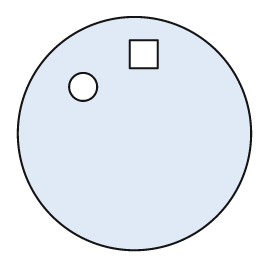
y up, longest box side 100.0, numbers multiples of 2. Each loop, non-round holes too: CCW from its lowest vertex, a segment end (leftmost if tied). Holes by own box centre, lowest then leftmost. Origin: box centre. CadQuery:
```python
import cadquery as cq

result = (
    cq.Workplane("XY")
    .moveTo(0.0, 0.0)
    .circle(50.0)
    .moveTo(-22.0, 20.0)
    .circle(6.0)
    .moveTo(-2.0, 28.0)
    .lineTo(10.0, 28.0)
    .lineTo(10.0, 40.0)
    .lineTo(-2.0, 40.0)
    .close()
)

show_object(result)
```